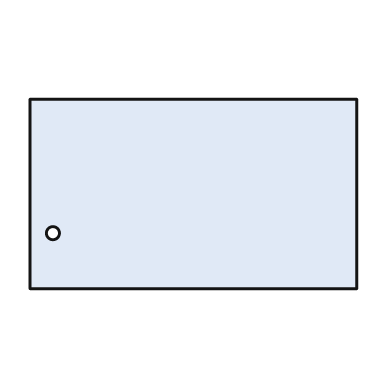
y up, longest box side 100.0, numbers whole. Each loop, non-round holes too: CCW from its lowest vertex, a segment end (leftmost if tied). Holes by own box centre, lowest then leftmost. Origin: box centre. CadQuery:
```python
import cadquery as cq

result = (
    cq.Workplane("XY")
    .moveTo(-50.0, -29.0)
    .lineTo(50.0, -29.0)
    .lineTo(50.0, 29.0)
    .lineTo(-50.0, 29.0)
    .close()
    .moveTo(-43.0, -12.0)
    .circle(2.0)
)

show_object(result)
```